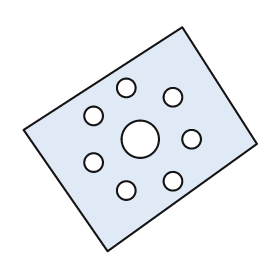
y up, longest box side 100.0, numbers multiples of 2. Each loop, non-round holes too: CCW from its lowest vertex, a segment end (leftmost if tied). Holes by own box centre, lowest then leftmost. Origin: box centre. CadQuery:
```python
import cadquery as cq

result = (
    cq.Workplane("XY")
    .moveTo(-14.0, -48.0)
    .lineTo(50.0, -2.0)
    .lineTo(18.0, 48.0)
    .lineTo(-50.0, 4.0)
    .close()
    .moveTo(-6.0, -22.0)
    .circle(4.0)
    .moveTo(14.0, -18.0)
    .circle(4.0)
    .moveTo(-20.0, -10.0)
    .circle(4.0)
    .moveTo(0.0, 0.0)
    .circle(8.0)
    .moveTo(22.0, 0.0)
    .circle(4.0)
    .moveTo(-20.0, 10.0)
    .circle(4.0)
    .moveTo(14.0, 18.0)
    .circle(4.0)
    .moveTo(-6.0, 22.0)
    .circle(4.0)
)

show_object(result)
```